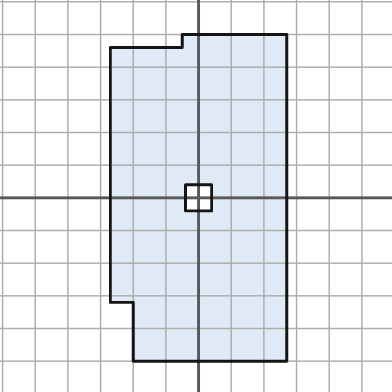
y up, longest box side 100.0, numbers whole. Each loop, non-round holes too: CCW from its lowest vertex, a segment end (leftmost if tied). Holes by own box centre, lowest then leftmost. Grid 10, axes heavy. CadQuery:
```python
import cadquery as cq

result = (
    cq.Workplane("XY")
    .moveTo(-20.0, -50.0)
    .lineTo(27.0, -50.0)
    .lineTo(27.0, 50.0)
    .lineTo(-5.0, 50.0)
    .lineTo(-5.0, 46.0)
    .lineTo(-27.0, 46.0)
    .lineTo(-27.0, -32.0)
    .lineTo(-20.0, -32.0)
    .close()
    .moveTo(-4.0, -4.0)
    .lineTo(4.0, -4.0)
    .lineTo(4.0, 4.0)
    .lineTo(-4.0, 4.0)
    .close()
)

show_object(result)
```